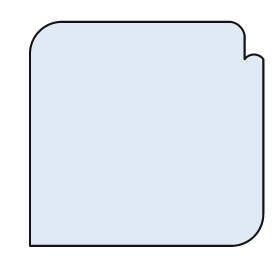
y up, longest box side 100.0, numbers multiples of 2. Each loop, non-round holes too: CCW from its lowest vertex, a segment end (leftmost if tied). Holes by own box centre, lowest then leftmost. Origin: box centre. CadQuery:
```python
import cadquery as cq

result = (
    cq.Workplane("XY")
    .moveTo(-50.0, -48.0)
    .lineTo(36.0, -48.0)
    .threePointArc((46.0, -44.0), (50.0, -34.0))
    .lineTo(50.0, 32.0)
    .threePointArc((46.0, 34.0), (42.0, 32.0))
    .lineTo(42.0, 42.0)
    .threePointArc((40.0, 46.0), (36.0, 48.0))
    .lineTo(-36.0, 48.0)
    .threePointArc((-46.0, 44.0), (-50.0, 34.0))
    .close()
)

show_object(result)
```